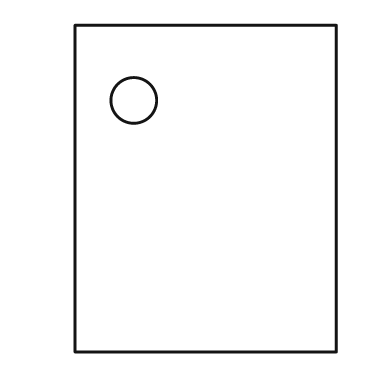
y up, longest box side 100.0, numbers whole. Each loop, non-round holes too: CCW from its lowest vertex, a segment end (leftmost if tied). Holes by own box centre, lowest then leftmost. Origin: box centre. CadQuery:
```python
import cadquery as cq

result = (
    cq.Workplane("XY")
    .moveTo(-40.0, -50.0)
    .lineTo(40.0, -50.0)
    .lineTo(40.0, 50.0)
    .lineTo(-40.0, 50.0)
    .close()
    .moveTo(-22.0, 27.0)
    .circle(7.0)
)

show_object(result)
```